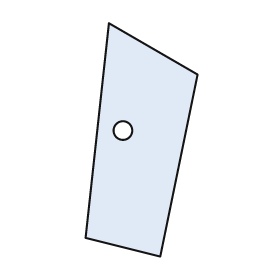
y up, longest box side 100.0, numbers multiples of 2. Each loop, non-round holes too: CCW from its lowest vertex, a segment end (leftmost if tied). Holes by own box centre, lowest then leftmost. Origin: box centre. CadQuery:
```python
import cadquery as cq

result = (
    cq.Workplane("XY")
    .moveTo(8.0, -50.0)
    .lineTo(24.0, 28.0)
    .lineTo(-14.0, 50.0)
    .lineTo(-24.0, -42.0)
    .close()
    .moveTo(-8.0, 4.0)
    .circle(4.0)
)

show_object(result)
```